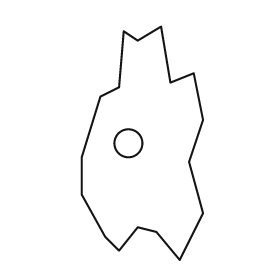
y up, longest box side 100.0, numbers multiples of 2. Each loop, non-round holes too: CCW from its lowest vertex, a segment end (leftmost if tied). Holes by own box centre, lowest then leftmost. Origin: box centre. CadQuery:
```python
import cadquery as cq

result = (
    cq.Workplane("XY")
    .moveTo(16.0, -50.0)
    .lineTo(26.0, -30.0)
    .lineTo(20.0, -8.0)
    .lineTo(26.0, 10.0)
    .lineTo(22.0, 30.0)
    .lineTo(12.0, 26.0)
    .lineTo(8.0, 50.0)
    .lineTo(-2.0, 44.0)
    .lineTo(-8.0, 48.0)
    .lineTo(-10.0, 24.0)
    .lineTo(-18.0, 20.0)
    .lineTo(-26.0, -6.0)
    .lineTo(-26.0, -22.0)
    .lineTo(-16.0, -40.0)
    .lineTo(-10.0, -46.0)
    .lineTo(-2.0, -36.0)
    .lineTo(6.0, -38.0)
    .close()
    .moveTo(-6.0, 0.0)
    .circle(6.0)
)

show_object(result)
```